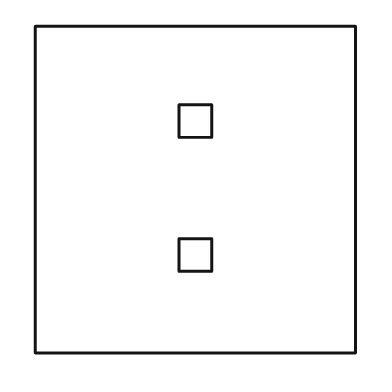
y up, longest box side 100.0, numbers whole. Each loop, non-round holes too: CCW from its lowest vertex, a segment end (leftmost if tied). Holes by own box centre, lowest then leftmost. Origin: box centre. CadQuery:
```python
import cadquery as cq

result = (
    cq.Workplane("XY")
    .moveTo(-49.0, -50.0)
    .lineTo(49.0, -50.0)
    .lineTo(49.0, 50.0)
    .lineTo(-49.0, 50.0)
    .close()
    .moveTo(-5.0, -25.0)
    .lineTo(5.0, -25.0)
    .lineTo(5.0, -15.0)
    .lineTo(-5.0, -15.0)
    .close()
    .moveTo(-5.0, 16.0)
    .lineTo(5.0, 16.0)
    .lineTo(5.0, 26.0)
    .lineTo(-5.0, 26.0)
    .close()
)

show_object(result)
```